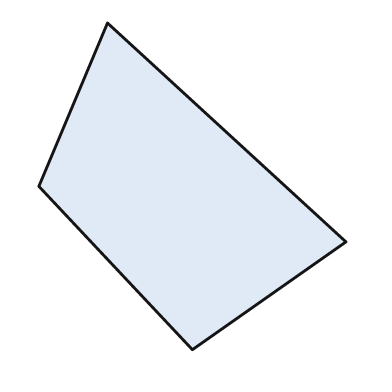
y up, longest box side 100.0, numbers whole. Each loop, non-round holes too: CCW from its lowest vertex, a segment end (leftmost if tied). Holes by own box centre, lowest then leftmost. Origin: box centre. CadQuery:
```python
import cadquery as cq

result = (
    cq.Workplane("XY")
    .moveTo(0.0, -50.0)
    .lineTo(47.0, -17.0)
    .lineTo(-26.0, 50.0)
    .lineTo(-47.0, 0.0)
    .close()
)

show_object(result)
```